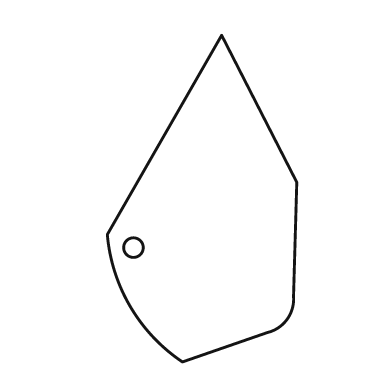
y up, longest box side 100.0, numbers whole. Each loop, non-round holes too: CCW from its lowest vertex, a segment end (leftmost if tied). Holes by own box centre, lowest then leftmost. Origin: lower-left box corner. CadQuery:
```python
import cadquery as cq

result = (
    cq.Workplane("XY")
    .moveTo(23.0, 0.0)
    .lineTo(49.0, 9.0)
    .threePointArc((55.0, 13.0), (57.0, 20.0))
    .lineTo(58.0, 55.0)
    .lineTo(35.0, 100.0)
    .lineTo(0.0, 39.0)
    .threePointArc((7.0, 17.0), (23.0, 0.0))
    .close()
    .moveTo(8.0, 35.0)
    .circle(3.0)
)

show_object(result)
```